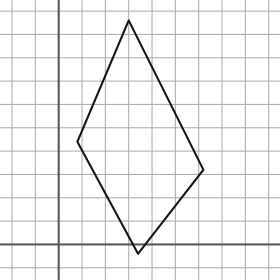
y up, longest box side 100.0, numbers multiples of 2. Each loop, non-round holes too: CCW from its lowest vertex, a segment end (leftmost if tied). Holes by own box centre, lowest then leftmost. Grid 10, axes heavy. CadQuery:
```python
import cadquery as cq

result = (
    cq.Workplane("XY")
    .moveTo(34.0, -4.0)
    .lineTo(62.0, 32.0)
    .lineTo(30.0, 96.0)
    .lineTo(8.0, 44.0)
    .close()
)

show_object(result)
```